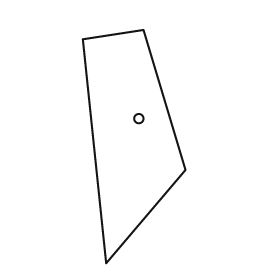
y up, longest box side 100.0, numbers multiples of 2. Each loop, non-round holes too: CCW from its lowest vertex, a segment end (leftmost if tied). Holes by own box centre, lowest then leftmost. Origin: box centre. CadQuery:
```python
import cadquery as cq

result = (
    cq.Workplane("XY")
    .moveTo(-12.0, -50.0)
    .lineTo(22.0, -10.0)
    .lineTo(4.0, 50.0)
    .lineTo(-22.0, 46.0)
    .close()
    .moveTo(2.0, 12.0)
    .circle(2.0)
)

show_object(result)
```